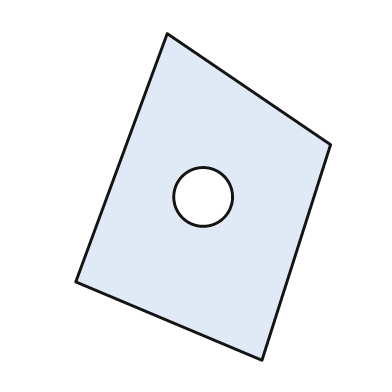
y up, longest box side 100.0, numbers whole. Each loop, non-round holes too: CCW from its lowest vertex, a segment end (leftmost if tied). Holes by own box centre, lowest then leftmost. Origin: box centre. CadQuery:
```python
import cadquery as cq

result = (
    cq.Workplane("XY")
    .moveTo(18.0, -50.0)
    .lineTo(39.0, 16.0)
    .lineTo(-11.0, 50.0)
    .lineTo(-39.0, -26.0)
    .close()
    .moveTo(0.0, 0.0)
    .circle(9.0)
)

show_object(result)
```